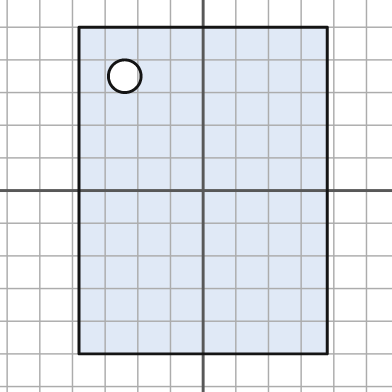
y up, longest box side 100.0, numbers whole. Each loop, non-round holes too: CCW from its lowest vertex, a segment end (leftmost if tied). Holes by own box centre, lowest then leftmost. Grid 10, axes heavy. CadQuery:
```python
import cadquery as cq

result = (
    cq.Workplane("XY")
    .moveTo(-38.0, -50.0)
    .lineTo(38.0, -50.0)
    .lineTo(38.0, 50.0)
    .lineTo(-38.0, 50.0)
    .close()
    .moveTo(-24.0, 35.0)
    .circle(5.0)
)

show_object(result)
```